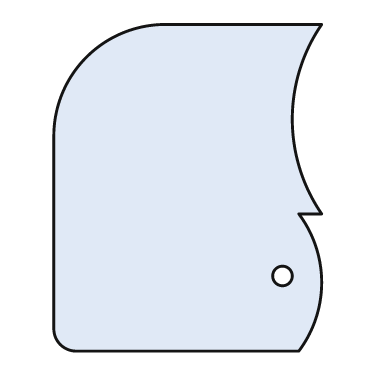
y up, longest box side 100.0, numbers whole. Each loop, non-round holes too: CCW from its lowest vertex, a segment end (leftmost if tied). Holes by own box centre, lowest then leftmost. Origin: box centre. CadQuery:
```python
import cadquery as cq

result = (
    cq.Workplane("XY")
    .moveTo(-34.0, -50.0)
    .lineTo(34.0, -50.0)
    .threePointArc((41.0, -29.0), (34.0, -8.0))
    .lineTo(41.0, -8.0)
    .threePointArc((32.0, 21.0), (41.0, 50.0))
    .lineTo(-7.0, 50.0)
    .threePointArc((-31.0, 40.0), (-41.0, 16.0))
    .lineTo(-41.0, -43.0)
    .threePointArc((-39.0, -48.0), (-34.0, -50.0))
    .close()
    .moveTo(29.0, -27.0)
    .circle(3.0)
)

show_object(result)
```